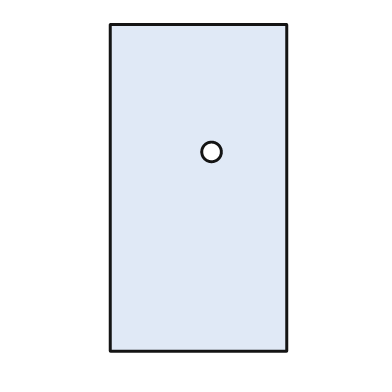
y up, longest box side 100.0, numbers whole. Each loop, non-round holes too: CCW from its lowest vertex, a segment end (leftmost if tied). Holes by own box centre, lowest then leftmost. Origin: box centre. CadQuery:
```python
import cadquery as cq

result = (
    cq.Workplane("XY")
    .moveTo(-27.0, -50.0)
    .lineTo(27.0, -50.0)
    .lineTo(27.0, 50.0)
    .lineTo(-27.0, 50.0)
    .close()
    .moveTo(4.0, 11.0)
    .circle(3.0)
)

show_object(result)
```